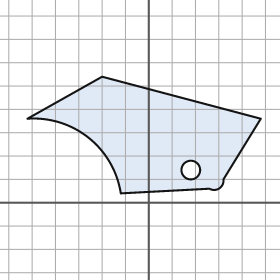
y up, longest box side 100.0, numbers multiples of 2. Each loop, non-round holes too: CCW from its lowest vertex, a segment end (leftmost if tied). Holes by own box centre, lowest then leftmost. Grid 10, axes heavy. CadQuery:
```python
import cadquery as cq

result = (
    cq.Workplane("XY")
    .moveTo(-12.0, 4.0)
    .lineTo(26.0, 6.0)
    .threePointArc((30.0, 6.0), (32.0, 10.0))
    .lineTo(48.0, 36.0)
    .lineTo(-20.0, 54.0)
    .lineTo(-52.0, 36.0)
    .threePointArc((-26.0, 28.0), (-12.0, 4.0))
    .close()
    .moveTo(18.0, 14.0)
    .circle(4.0)
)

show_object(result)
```